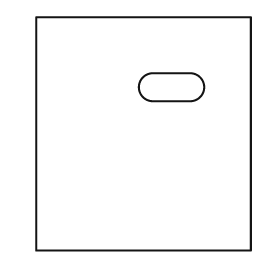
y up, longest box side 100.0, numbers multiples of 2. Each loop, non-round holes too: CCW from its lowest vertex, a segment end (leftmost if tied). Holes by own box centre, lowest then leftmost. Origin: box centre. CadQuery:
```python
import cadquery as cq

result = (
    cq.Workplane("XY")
    .moveTo(-46.0, -50.0)
    .lineTo(46.0, -50.0)
    .lineTo(46.0, 50.0)
    .lineTo(-46.0, 50.0)
    .close()
    .moveTo(4.0, 14.0)
    .lineTo(20.0, 14.0)
    .threePointArc((26.0, 20.0), (20.0, 26.0))
    .lineTo(4.0, 26.0)
    .threePointArc((-2.0, 20.0), (4.0, 14.0))
    .close()
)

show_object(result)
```